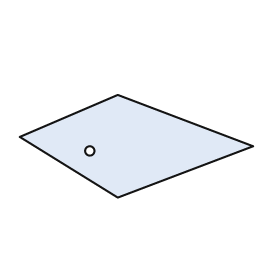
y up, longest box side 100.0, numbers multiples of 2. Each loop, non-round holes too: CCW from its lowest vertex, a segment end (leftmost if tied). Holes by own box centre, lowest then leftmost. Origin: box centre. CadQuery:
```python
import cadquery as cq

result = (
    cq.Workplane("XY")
    .moveTo(-8.0, -22.0)
    .lineTo(50.0, 0.0)
    .lineTo(-8.0, 22.0)
    .lineTo(-50.0, 4.0)
    .close()
    .moveTo(-20.0, -2.0)
    .circle(2.0)
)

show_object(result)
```